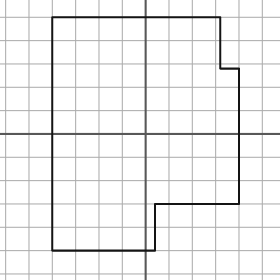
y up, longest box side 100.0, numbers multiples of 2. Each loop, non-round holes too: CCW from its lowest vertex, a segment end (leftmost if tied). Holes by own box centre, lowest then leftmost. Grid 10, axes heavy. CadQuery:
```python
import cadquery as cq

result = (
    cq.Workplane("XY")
    .moveTo(-40.0, -50.0)
    .lineTo(4.0, -50.0)
    .lineTo(4.0, -30.0)
    .lineTo(40.0, -30.0)
    .lineTo(40.0, 28.0)
    .lineTo(32.0, 28.0)
    .lineTo(32.0, 50.0)
    .lineTo(-40.0, 50.0)
    .close()
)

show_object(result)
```